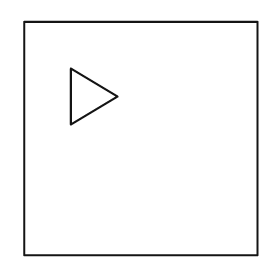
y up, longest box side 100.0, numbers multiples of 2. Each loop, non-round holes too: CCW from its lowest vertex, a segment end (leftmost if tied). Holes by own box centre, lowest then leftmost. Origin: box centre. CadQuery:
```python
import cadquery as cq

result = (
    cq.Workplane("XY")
    .moveTo(-50.0, -50.0)
    .lineTo(50.0, -50.0)
    .lineTo(50.0, 50.0)
    .lineTo(-50.0, 50.0)
    .close()
    .moveTo(-30.0, 6.0)
    .lineTo(-10.0, 18.0)
    .lineTo(-30.0, 30.0)
    .close()
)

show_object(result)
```